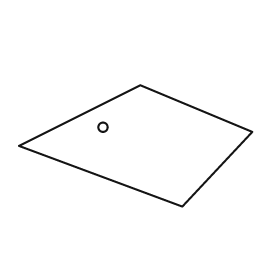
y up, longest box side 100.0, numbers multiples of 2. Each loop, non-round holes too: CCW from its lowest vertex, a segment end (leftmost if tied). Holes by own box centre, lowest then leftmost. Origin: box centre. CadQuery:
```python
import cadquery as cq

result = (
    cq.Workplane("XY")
    .moveTo(20.0, -26.0)
    .lineTo(50.0, 6.0)
    .lineTo(2.0, 26.0)
    .lineTo(-50.0, 0.0)
    .close()
    .moveTo(-14.0, 8.0)
    .circle(2.0)
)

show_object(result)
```